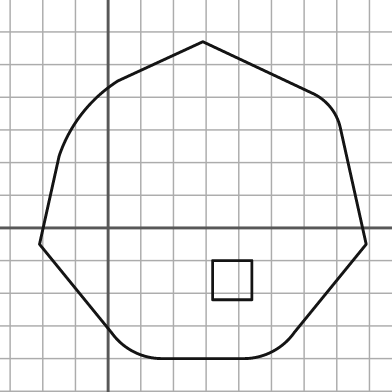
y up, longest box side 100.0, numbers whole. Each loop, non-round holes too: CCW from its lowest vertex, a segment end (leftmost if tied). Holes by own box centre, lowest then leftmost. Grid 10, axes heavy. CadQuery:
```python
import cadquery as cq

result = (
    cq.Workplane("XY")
    .moveTo(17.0, -40.0)
    .lineTo(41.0, -40.0)
    .threePointArc((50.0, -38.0), (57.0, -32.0))
    .lineTo(79.0, -5.0)
    .lineTo(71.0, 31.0)
    .threePointArc((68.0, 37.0), (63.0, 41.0))
    .lineTo(29.0, 57.0)
    .lineTo(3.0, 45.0)
    .threePointArc((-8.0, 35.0), (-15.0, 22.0))
    .lineTo(-21.0, -5.0)
    .lineTo(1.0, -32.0)
    .threePointArc((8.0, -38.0), (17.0, -40.0))
    .close()
    .moveTo(32.0, -22.0)
    .lineTo(44.0, -22.0)
    .lineTo(44.0, -10.0)
    .lineTo(32.0, -10.0)
    .close()
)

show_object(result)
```